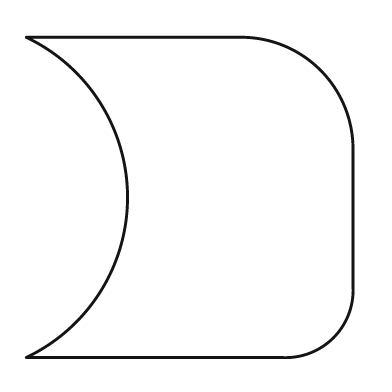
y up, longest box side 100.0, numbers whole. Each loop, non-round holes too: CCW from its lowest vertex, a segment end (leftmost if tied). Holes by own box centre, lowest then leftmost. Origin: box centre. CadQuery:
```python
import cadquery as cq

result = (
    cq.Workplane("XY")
    .moveTo(-50.0, -49.0)
    .lineTo(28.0, -49.0)
    .threePointArc((44.0, -43.0), (50.0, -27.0))
    .lineTo(50.0, 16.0)
    .threePointArc((40.0, 39.0), (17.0, 49.0))
    .lineTo(-50.0, 49.0)
    .threePointArc((-19.0, 0.0), (-50.0, -49.0))
    .close()
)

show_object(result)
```